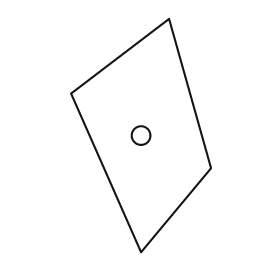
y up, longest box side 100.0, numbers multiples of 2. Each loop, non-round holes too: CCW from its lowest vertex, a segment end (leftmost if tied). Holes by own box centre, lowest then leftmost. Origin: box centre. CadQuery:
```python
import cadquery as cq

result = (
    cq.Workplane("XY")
    .moveTo(0.0, -50.0)
    .lineTo(30.0, -14.0)
    .lineTo(12.0, 50.0)
    .lineTo(-30.0, 18.0)
    .close()
    .moveTo(0.0, 0.0)
    .circle(4.0)
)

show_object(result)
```